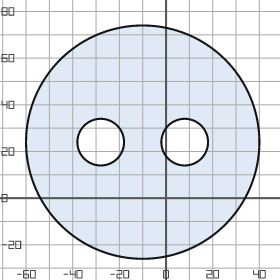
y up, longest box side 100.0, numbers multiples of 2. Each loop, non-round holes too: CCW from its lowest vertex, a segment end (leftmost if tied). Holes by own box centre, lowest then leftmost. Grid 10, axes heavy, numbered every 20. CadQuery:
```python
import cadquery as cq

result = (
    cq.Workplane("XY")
    .moveTo(-10.0, 24.0)
    .circle(50.0)
    .moveTo(-28.0, 24.0)
    .circle(10.0)
    .moveTo(8.0, 24.0)
    .circle(10.0)
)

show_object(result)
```